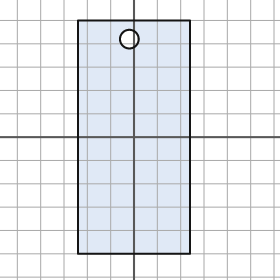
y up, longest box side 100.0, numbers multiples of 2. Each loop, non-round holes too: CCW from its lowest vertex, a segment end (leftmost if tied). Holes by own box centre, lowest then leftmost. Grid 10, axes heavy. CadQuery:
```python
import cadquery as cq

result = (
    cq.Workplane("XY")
    .moveTo(-24.0, -50.0)
    .lineTo(24.0, -50.0)
    .lineTo(24.0, 50.0)
    .lineTo(-24.0, 50.0)
    .close()
    .moveTo(-2.0, 42.0)
    .circle(4.0)
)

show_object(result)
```